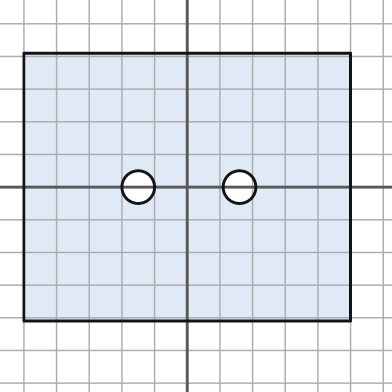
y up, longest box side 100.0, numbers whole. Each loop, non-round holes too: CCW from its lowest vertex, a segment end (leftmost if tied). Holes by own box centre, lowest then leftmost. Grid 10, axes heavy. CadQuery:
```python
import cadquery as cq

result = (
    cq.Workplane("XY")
    .moveTo(-50.0, -41.0)
    .lineTo(50.0, -41.0)
    .lineTo(50.0, 41.0)
    .lineTo(-50.0, 41.0)
    .close()
    .moveTo(-15.0, 0.0)
    .circle(5.0)
    .moveTo(16.0, 0.0)
    .circle(5.0)
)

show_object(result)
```